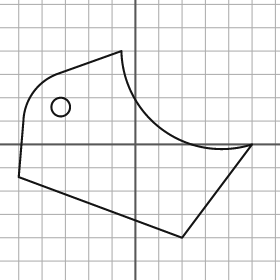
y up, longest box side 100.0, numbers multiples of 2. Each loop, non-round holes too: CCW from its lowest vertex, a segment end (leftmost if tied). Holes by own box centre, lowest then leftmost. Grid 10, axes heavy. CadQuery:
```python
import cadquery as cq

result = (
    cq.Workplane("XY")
    .moveTo(20.0, -40.0)
    .lineTo(50.0, 0.0)
    .threePointArc((12.0, 6.0), (-6.0, 40.0))
    .lineTo(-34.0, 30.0)
    .threePointArc((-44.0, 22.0), (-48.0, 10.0))
    .lineTo(-50.0, -14.0)
    .close()
    .moveTo(-32.0, 16.0)
    .circle(4.0)
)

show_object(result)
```